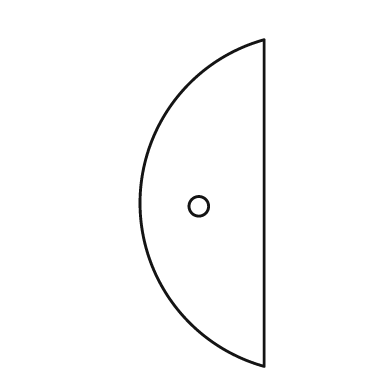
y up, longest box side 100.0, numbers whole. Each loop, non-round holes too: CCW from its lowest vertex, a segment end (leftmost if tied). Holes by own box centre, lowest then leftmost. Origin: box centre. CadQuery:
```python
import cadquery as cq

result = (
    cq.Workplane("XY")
    .moveTo(19.0, -50.0)
    .lineTo(19.0, 50.0)
    .threePointArc((-19.0, 0.0), (19.0, -50.0))
    .close()
    .moveTo(-1.0, -1.0)
    .circle(3.0)
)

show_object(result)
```